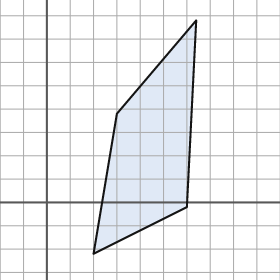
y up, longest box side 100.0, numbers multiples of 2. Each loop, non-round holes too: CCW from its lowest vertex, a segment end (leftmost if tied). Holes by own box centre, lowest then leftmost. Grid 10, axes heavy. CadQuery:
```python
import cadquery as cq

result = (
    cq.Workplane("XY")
    .moveTo(20.0, -22.0)
    .lineTo(60.0, -2.0)
    .lineTo(64.0, 78.0)
    .lineTo(30.0, 38.0)
    .close()
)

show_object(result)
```